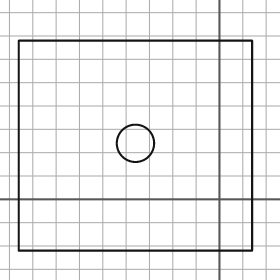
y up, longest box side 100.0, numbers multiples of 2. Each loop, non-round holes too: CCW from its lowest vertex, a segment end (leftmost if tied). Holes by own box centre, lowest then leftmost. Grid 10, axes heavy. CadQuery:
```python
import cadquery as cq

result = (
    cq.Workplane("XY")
    .moveTo(-86.0, -22.0)
    .lineTo(14.0, -22.0)
    .lineTo(14.0, 68.0)
    .lineTo(-86.0, 68.0)
    .close()
    .moveTo(-36.0, 24.0)
    .circle(8.0)
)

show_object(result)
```